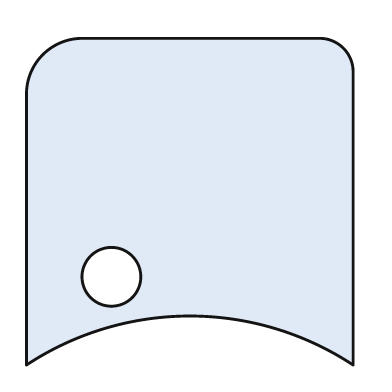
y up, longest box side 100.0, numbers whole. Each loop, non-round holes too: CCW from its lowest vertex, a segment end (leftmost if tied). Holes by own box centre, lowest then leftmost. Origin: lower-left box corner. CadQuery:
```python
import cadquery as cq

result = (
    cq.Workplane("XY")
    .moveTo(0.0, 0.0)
    .threePointArc((50.0, 15.0), (100.0, 0.0))
    .lineTo(100.0, 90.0)
    .threePointArc((97.0, 97.0), (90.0, 100.0))
    .lineTo(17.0, 100.0)
    .threePointArc((5.0, 95.0), (0.0, 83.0))
    .close()
    .moveTo(26.0, 27.0)
    .circle(9.0)
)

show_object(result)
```